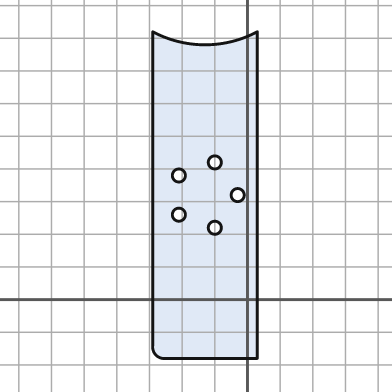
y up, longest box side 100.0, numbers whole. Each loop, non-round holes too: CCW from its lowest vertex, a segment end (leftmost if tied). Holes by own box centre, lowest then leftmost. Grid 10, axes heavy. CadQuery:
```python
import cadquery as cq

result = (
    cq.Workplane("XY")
    .moveTo(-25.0, -18.0)
    .lineTo(3.0, -18.0)
    .lineTo(3.0, 82.0)
    .threePointArc((-13.0, 78.0), (-29.0, 82.0))
    .lineTo(-29.0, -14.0)
    .threePointArc((-28.0, -17.0), (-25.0, -18.0))
    .close()
    .moveTo(-10.0, 22.0)
    .circle(2.0)
    .moveTo(-21.0, 26.0)
    .circle(2.0)
    .moveTo(-3.0, 32.0)
    .circle(2.0)
    .moveTo(-21.0, 38.0)
    .circle(2.0)
    .moveTo(-10.0, 42.0)
    .circle(2.0)
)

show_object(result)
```